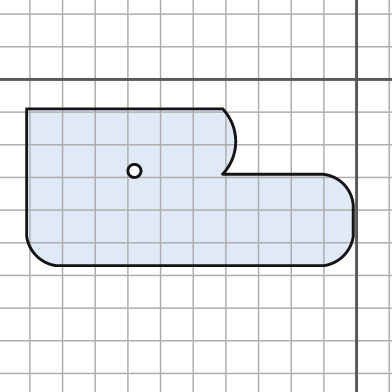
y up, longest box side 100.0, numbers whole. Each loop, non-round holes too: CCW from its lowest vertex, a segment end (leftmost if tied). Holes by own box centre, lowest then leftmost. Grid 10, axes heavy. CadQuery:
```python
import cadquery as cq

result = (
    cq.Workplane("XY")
    .moveTo(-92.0, -57.0)
    .lineTo(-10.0, -57.0)
    .threePointArc((-4.0, -54.0), (-1.0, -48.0))
    .lineTo(-1.0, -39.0)
    .threePointArc((-4.0, -32.0), (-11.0, -29.0))
    .lineTo(-41.0, -29.0)
    .threePointArc((-37.0, -19.0), (-41.0, -9.0))
    .lineTo(-101.0, -9.0)
    .lineTo(-101.0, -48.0)
    .threePointArc((-98.0, -54.0), (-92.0, -57.0))
    .close()
    .moveTo(-68.0, -28.0)
    .circle(2.0)
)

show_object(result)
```